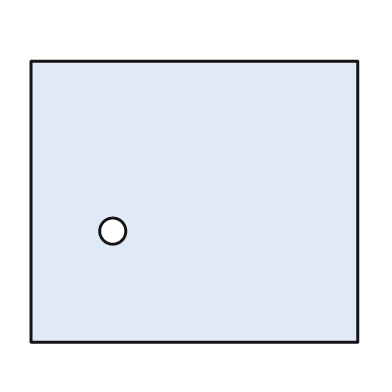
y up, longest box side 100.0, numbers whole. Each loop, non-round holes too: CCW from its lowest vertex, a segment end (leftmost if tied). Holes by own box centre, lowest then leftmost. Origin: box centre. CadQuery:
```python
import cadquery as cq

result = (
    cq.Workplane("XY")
    .moveTo(-50.0, -43.0)
    .lineTo(50.0, -43.0)
    .lineTo(50.0, 43.0)
    .lineTo(-50.0, 43.0)
    .close()
    .moveTo(-25.0, -9.0)
    .circle(4.0)
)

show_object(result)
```